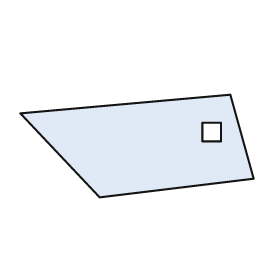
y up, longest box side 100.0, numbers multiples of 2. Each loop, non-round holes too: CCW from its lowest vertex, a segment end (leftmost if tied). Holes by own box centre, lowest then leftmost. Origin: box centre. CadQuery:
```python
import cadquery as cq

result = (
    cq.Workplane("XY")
    .moveTo(-16.0, -22.0)
    .lineTo(50.0, -14.0)
    .lineTo(40.0, 22.0)
    .lineTo(-50.0, 14.0)
    .close()
    .moveTo(28.0, 2.0)
    .lineTo(36.0, 2.0)
    .lineTo(36.0, 10.0)
    .lineTo(28.0, 10.0)
    .close()
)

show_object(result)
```